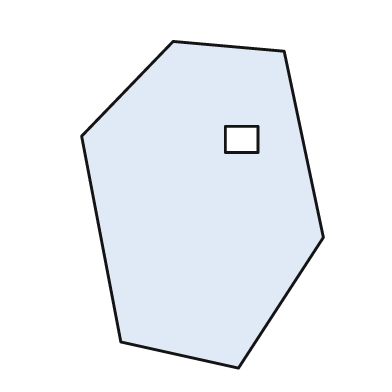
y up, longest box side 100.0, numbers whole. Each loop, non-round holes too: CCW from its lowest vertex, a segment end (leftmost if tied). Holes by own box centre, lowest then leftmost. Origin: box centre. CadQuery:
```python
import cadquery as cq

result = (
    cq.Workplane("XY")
    .moveTo(11.0, -50.0)
    .lineTo(37.0, -10.0)
    .lineTo(25.0, 47.0)
    .lineTo(-9.0, 50.0)
    .lineTo(-37.0, 21.0)
    .lineTo(-25.0, -42.0)
    .close()
    .moveTo(7.0, 16.0)
    .lineTo(17.0, 16.0)
    .lineTo(17.0, 24.0)
    .lineTo(7.0, 24.0)
    .close()
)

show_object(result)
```